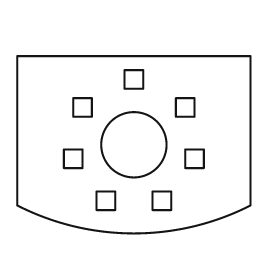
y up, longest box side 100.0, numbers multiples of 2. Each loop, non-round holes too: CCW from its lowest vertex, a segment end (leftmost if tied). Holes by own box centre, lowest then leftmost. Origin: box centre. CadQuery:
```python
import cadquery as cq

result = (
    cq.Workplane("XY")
    .moveTo(-50.0, -26.0)
    .threePointArc((0.0, -38.0), (50.0, -26.0))
    .lineTo(50.0, 38.0)
    .lineTo(-50.0, 38.0)
    .close()
    .moveTo(-16.0, -28.0)
    .lineTo(-8.0, -28.0)
    .lineTo(-8.0, -20.0)
    .lineTo(-16.0, -20.0)
    .close()
    .moveTo(8.0, -28.0)
    .lineTo(16.0, -28.0)
    .lineTo(16.0, -20.0)
    .lineTo(8.0, -20.0)
    .close()
    .moveTo(-30.0, -10.0)
    .lineTo(-22.0, -10.0)
    .lineTo(-22.0, -2.0)
    .lineTo(-30.0, -2.0)
    .close()
    .moveTo(22.0, -10.0)
    .lineTo(30.0, -10.0)
    .lineTo(30.0, -2.0)
    .lineTo(22.0, -2.0)
    .close()
    .moveTo(0.0, 0.0)
    .circle(14.0)
    .moveTo(-26.0, 12.0)
    .lineTo(-18.0, 12.0)
    .lineTo(-18.0, 20.0)
    .lineTo(-26.0, 20.0)
    .close()
    .moveTo(18.0, 12.0)
    .lineTo(26.0, 12.0)
    .lineTo(26.0, 20.0)
    .lineTo(18.0, 20.0)
    .close()
    .moveTo(-4.0, 24.0)
    .lineTo(4.0, 24.0)
    .lineTo(4.0, 32.0)
    .lineTo(-4.0, 32.0)
    .close()
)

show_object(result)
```